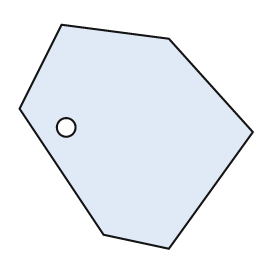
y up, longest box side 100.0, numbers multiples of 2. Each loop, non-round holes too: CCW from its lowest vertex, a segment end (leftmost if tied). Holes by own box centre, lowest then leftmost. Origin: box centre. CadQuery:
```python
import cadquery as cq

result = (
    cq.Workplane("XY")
    .moveTo(14.0, -48.0)
    .lineTo(50.0, 2.0)
    .lineTo(14.0, 42.0)
    .lineTo(-32.0, 48.0)
    .lineTo(-50.0, 12.0)
    .lineTo(-14.0, -42.0)
    .close()
    .moveTo(-30.0, 4.0)
    .circle(4.0)
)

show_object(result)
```